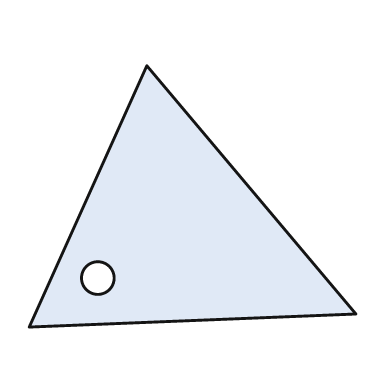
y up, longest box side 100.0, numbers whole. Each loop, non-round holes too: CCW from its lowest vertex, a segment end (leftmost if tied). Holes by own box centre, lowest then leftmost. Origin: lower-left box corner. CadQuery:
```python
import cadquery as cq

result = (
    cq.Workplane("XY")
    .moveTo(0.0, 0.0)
    .lineTo(100.0, 4.0)
    .lineTo(36.0, 80.0)
    .close()
    .moveTo(21.0, 15.0)
    .circle(5.0)
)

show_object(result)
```